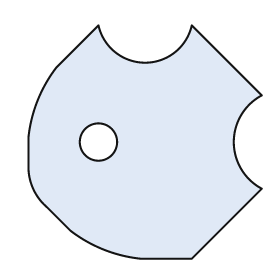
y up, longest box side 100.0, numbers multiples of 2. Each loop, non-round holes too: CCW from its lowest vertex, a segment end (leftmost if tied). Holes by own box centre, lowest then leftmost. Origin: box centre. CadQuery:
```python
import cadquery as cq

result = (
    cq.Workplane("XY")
    .moveTo(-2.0, -50.0)
    .lineTo(20.0, -50.0)
    .lineTo(50.0, -20.0)
    .threePointArc((38.0, 0.0), (50.0, 20.0))
    .lineTo(20.0, 50.0)
    .threePointArc((0.0, 34.0), (-20.0, 50.0))
    .lineTo(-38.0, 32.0)
    .threePointArc((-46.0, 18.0), (-50.0, 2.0))
    .lineTo(-50.0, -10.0)
    .threePointArc((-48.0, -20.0), (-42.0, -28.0))
    .lineTo(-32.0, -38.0)
    .threePointArc((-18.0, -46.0), (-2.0, -50.0))
    .close()
    .moveTo(-20.0, 0.0)
    .circle(8.0)
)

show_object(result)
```